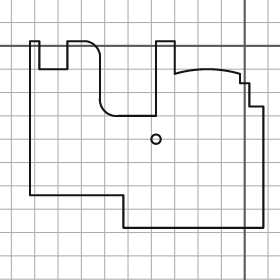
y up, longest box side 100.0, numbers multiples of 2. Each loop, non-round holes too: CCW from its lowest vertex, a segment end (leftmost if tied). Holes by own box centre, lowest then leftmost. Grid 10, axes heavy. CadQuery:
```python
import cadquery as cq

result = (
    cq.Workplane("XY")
    .moveTo(-52.0, -78.0)
    .lineTo(8.0, -78.0)
    .lineTo(8.0, -26.0)
    .lineTo(2.0, -26.0)
    .lineTo(2.0, -16.0)
    .lineTo(-2.0, -16.0)
    .lineTo(-2.0, -12.0)
    .threePointArc((-16.0, -10.0), (-30.0, -12.0))
    .lineTo(-30.0, 2.0)
    .lineTo(-38.0, 2.0)
    .lineTo(-38.0, -30.0)
    .lineTo(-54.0, -30.0)
    .threePointArc((-60.0, -28.0), (-62.0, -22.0))
    .lineTo(-62.0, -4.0)
    .threePointArc((-64.0, 0.0), (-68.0, 2.0))
    .lineTo(-76.0, 2.0)
    .lineTo(-76.0, -10.0)
    .lineTo(-88.0, -10.0)
    .lineTo(-88.0, 2.0)
    .lineTo(-92.0, 2.0)
    .lineTo(-92.0, -64.0)
    .lineTo(-52.0, -64.0)
    .close()
    .moveTo(-38.0, -40.0)
    .circle(2.0)
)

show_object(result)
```